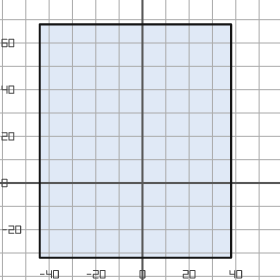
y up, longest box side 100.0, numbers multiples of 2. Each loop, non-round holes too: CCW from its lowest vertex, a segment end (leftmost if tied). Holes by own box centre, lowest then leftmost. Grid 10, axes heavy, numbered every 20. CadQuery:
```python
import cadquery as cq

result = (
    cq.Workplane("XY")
    .moveTo(-44.0, -32.0)
    .lineTo(38.0, -32.0)
    .lineTo(38.0, 68.0)
    .lineTo(-44.0, 68.0)
    .close()
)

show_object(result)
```